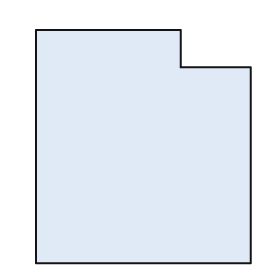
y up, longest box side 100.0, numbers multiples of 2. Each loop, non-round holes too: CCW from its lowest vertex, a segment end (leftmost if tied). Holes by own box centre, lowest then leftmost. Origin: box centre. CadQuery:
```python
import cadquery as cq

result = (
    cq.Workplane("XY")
    .moveTo(-46.0, -50.0)
    .lineTo(46.0, -50.0)
    .lineTo(46.0, 34.0)
    .lineTo(16.0, 34.0)
    .lineTo(16.0, 50.0)
    .lineTo(-46.0, 50.0)
    .close()
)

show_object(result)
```